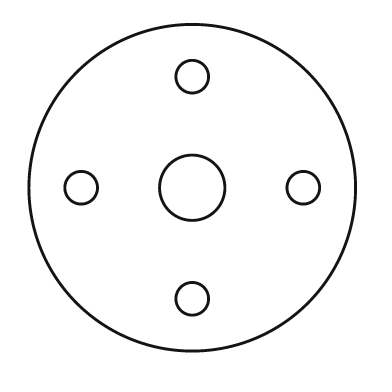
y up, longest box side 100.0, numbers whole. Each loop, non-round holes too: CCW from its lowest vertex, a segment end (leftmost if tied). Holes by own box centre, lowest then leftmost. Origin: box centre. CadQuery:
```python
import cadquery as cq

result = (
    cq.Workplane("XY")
    .moveTo(0.0, 0.0)
    .circle(50.0)
    .moveTo(0.0, -34.0)
    .circle(5.0)
    .moveTo(-34.0, 0.0)
    .circle(5.0)
    .moveTo(0.0, 0.0)
    .circle(10.0)
    .moveTo(34.0, 0.0)
    .circle(5.0)
    .moveTo(0.0, 34.0)
    .circle(5.0)
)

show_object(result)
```